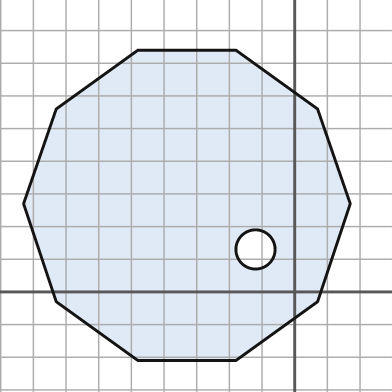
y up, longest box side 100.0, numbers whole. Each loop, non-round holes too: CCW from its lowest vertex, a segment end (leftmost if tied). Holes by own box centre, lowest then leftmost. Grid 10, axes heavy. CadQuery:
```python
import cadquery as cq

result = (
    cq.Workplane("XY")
    .moveTo(-48.0, -21.0)
    .lineTo(-18.0, -21.0)
    .lineTo(7.0, -3.0)
    .lineTo(17.0, 27.0)
    .lineTo(7.0, 56.0)
    .lineTo(-18.0, 74.0)
    .lineTo(-48.0, 74.0)
    .lineTo(-73.0, 56.0)
    .lineTo(-83.0, 27.0)
    .lineTo(-73.0, -3.0)
    .close()
    .moveTo(-12.0, 13.0)
    .circle(6.0)
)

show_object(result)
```